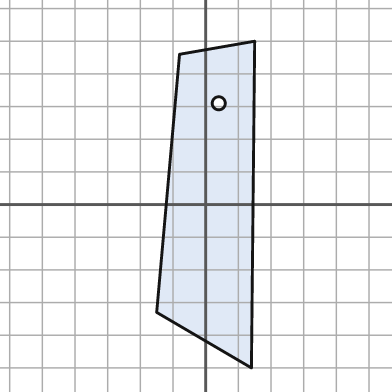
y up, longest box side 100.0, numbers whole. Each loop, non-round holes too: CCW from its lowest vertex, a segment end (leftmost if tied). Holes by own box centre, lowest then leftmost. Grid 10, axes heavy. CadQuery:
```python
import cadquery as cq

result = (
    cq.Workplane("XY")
    .moveTo(14.0, -50.0)
    .lineTo(15.0, 50.0)
    .lineTo(-8.0, 46.0)
    .lineTo(-15.0, -33.0)
    .close()
    .moveTo(4.0, 31.0)
    .circle(2.0)
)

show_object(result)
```